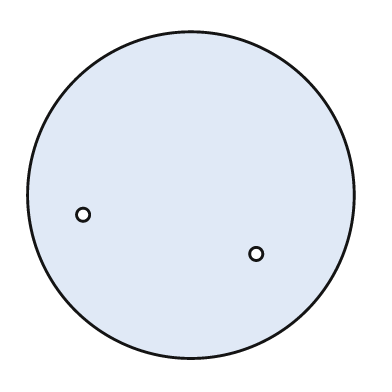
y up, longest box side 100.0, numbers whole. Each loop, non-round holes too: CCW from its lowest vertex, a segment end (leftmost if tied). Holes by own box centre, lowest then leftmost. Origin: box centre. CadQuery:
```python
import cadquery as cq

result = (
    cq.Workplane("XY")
    .moveTo(0.0, 0.0)
    .circle(50.0)
    .moveTo(20.0, -18.0)
    .circle(2.0)
    .moveTo(-33.0, -6.0)
    .circle(2.0)
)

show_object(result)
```